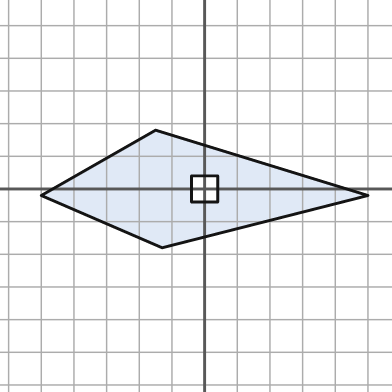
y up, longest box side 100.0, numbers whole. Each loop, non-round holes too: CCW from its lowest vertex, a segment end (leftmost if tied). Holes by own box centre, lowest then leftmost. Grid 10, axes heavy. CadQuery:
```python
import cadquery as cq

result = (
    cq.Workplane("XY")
    .moveTo(-13.0, -18.0)
    .lineTo(50.0, -2.0)
    .lineTo(-15.0, 18.0)
    .lineTo(-50.0, -2.0)
    .close()
    .moveTo(-4.0, -4.0)
    .lineTo(4.0, -4.0)
    .lineTo(4.0, 4.0)
    .lineTo(-4.0, 4.0)
    .close()
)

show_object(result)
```